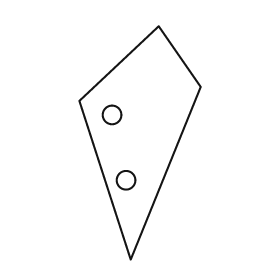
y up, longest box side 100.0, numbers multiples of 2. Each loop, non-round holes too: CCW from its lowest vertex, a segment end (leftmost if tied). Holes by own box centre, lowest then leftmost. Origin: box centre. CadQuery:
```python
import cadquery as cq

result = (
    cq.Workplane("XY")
    .moveTo(-4.0, -50.0)
    .lineTo(26.0, 24.0)
    .lineTo(8.0, 50.0)
    .lineTo(-26.0, 18.0)
    .close()
    .moveTo(-6.0, -16.0)
    .circle(4.0)
    .moveTo(-12.0, 12.0)
    .circle(4.0)
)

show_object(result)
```